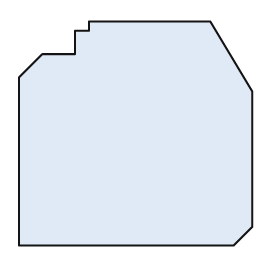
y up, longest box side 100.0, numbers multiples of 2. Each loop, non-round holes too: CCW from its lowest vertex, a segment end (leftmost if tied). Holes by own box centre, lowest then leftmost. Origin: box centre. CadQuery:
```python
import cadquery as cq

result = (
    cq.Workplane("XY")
    .moveTo(-50.0, -48.0)
    .lineTo(42.0, -48.0)
    .lineTo(50.0, -40.0)
    .lineTo(50.0, 18.0)
    .lineTo(32.0, 48.0)
    .lineTo(-20.0, 48.0)
    .lineTo(-20.0, 44.0)
    .lineTo(-26.0, 44.0)
    .lineTo(-26.0, 34.0)
    .lineTo(-40.0, 34.0)
    .lineTo(-50.0, 24.0)
    .close()
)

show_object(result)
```